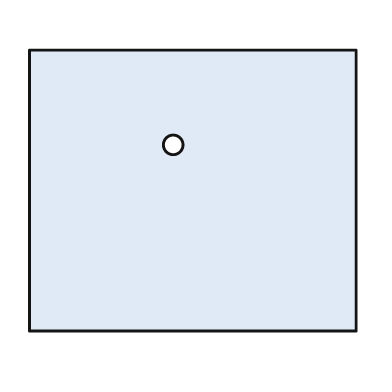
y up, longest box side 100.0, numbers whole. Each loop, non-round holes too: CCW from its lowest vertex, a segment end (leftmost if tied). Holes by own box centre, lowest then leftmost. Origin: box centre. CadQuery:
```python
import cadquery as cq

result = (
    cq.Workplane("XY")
    .moveTo(-50.0, -43.0)
    .lineTo(50.0, -43.0)
    .lineTo(50.0, 43.0)
    .lineTo(-50.0, 43.0)
    .close()
    .moveTo(-6.0, 14.0)
    .circle(3.0)
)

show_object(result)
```